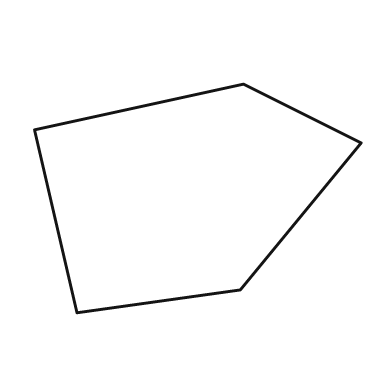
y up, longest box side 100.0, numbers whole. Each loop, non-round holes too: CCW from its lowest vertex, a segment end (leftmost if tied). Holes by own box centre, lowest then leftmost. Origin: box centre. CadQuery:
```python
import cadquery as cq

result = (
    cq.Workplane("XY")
    .moveTo(-37.0, -35.0)
    .lineTo(13.0, -28.0)
    .lineTo(50.0, 17.0)
    .lineTo(14.0, 35.0)
    .lineTo(-50.0, 21.0)
    .close()
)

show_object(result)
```